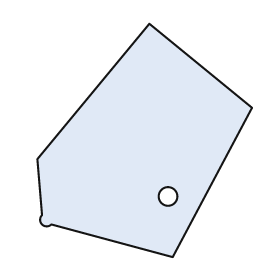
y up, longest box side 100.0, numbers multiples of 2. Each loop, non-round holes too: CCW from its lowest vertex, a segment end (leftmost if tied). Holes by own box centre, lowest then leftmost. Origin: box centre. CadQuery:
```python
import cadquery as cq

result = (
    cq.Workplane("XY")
    .moveTo(12.0, -50.0)
    .lineTo(46.0, 14.0)
    .lineTo(2.0, 50.0)
    .lineTo(-46.0, -8.0)
    .lineTo(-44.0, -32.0)
    .threePointArc((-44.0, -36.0), (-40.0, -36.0))
    .close()
    .moveTo(10.0, -24.0)
    .circle(4.0)
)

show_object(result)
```